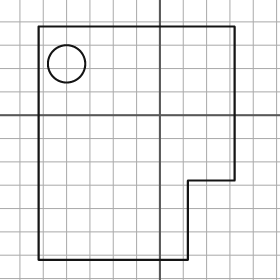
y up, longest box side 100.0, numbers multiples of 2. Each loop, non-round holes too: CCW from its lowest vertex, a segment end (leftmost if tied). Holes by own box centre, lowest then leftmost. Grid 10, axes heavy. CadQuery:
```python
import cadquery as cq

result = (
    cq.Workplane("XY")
    .moveTo(-52.0, -62.0)
    .lineTo(12.0, -62.0)
    .lineTo(12.0, -28.0)
    .lineTo(32.0, -28.0)
    .lineTo(32.0, 38.0)
    .lineTo(-52.0, 38.0)
    .close()
    .moveTo(-40.0, 22.0)
    .circle(8.0)
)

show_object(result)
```